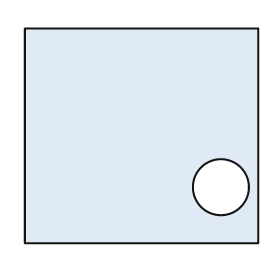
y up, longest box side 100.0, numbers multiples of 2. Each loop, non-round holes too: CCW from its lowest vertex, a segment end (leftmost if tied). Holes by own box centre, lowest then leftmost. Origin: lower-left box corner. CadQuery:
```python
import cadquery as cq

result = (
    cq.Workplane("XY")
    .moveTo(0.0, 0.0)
    .lineTo(100.0, 0.0)
    .lineTo(100.0, 92.0)
    .lineTo(0.0, 92.0)
    .close()
    .moveTo(84.0, 24.0)
    .circle(12.0)
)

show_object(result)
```